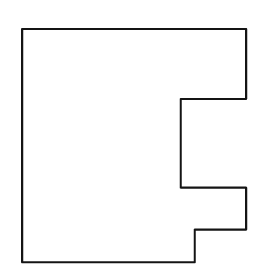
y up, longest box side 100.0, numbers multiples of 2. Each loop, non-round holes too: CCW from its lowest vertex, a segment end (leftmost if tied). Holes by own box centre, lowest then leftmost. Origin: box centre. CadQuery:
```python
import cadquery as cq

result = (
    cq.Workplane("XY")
    .moveTo(-48.0, -50.0)
    .lineTo(26.0, -50.0)
    .lineTo(26.0, -36.0)
    .lineTo(48.0, -36.0)
    .lineTo(48.0, -18.0)
    .lineTo(20.0, -18.0)
    .lineTo(20.0, 20.0)
    .lineTo(48.0, 20.0)
    .lineTo(48.0, 50.0)
    .lineTo(-48.0, 50.0)
    .close()
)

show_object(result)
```